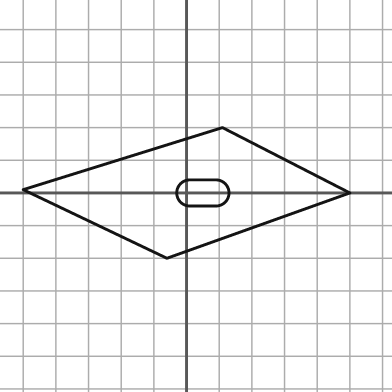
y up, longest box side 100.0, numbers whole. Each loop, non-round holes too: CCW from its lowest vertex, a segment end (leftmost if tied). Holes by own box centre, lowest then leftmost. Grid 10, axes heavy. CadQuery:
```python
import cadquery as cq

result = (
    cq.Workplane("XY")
    .moveTo(-6.0, -20.0)
    .lineTo(50.0, 0.0)
    .lineTo(11.0, 20.0)
    .lineTo(-50.0, 1.0)
    .close()
    .moveTo(1.0, -4.0)
    .lineTo(9.0, -4.0)
    .threePointArc((13.0, 0.0), (9.0, 4.0))
    .lineTo(1.0, 4.0)
    .threePointArc((-3.0, 0.0), (1.0, -4.0))
    .close()
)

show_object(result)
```